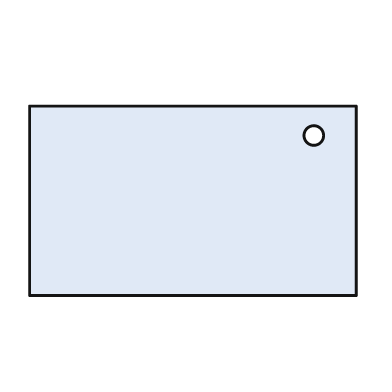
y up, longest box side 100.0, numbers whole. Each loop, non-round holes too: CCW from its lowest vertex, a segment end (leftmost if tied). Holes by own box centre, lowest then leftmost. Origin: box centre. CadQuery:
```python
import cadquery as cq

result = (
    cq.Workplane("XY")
    .moveTo(-50.0, -29.0)
    .lineTo(50.0, -29.0)
    .lineTo(50.0, 29.0)
    .lineTo(-50.0, 29.0)
    .close()
    .moveTo(37.0, 20.0)
    .circle(3.0)
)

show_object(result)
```